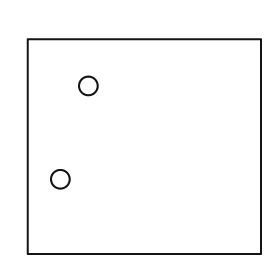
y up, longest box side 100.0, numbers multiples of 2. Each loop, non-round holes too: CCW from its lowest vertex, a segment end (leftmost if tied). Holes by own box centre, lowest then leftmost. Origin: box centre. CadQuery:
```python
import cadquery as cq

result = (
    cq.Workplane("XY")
    .moveTo(-50.0, -46.0)
    .lineTo(50.0, -46.0)
    .lineTo(50.0, 46.0)
    .lineTo(-50.0, 46.0)
    .close()
    .moveTo(-36.0, -14.0)
    .circle(4.0)
    .moveTo(-24.0, 26.0)
    .circle(4.0)
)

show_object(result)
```